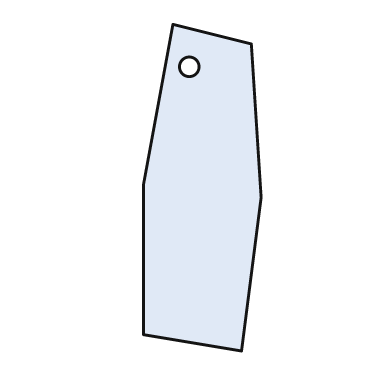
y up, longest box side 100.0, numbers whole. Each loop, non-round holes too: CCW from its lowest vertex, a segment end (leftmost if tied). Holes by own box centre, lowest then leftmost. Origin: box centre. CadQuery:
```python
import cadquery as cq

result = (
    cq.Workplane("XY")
    .moveTo(12.0, -50.0)
    .lineTo(18.0, -3.0)
    .lineTo(15.0, 44.0)
    .lineTo(-9.0, 50.0)
    .lineTo(-18.0, 1.0)
    .lineTo(-18.0, -45.0)
    .close()
    .moveTo(-4.0, 37.0)
    .circle(3.0)
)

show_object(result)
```